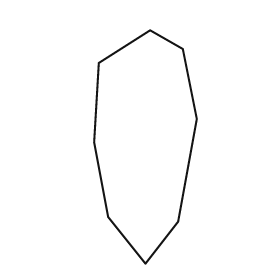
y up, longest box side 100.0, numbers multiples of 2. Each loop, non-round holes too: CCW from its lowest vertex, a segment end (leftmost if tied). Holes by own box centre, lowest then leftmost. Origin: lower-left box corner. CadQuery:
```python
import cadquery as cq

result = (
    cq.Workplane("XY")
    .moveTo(22.0, 0.0)
    .lineTo(36.0, 18.0)
    .lineTo(44.0, 62.0)
    .lineTo(38.0, 92.0)
    .lineTo(24.0, 100.0)
    .lineTo(2.0, 86.0)
    .lineTo(0.0, 52.0)
    .lineTo(6.0, 20.0)
    .close()
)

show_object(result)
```